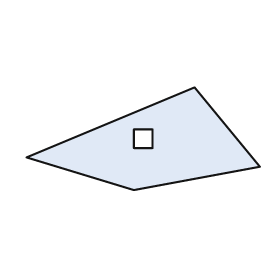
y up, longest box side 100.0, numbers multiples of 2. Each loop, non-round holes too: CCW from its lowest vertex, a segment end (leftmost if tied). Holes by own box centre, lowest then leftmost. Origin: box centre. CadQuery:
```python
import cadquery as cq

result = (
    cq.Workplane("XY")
    .moveTo(-4.0, -22.0)
    .lineTo(50.0, -12.0)
    .lineTo(22.0, 22.0)
    .lineTo(-50.0, -8.0)
    .close()
    .moveTo(-4.0, -4.0)
    .lineTo(4.0, -4.0)
    .lineTo(4.0, 4.0)
    .lineTo(-4.0, 4.0)
    .close()
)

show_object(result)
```